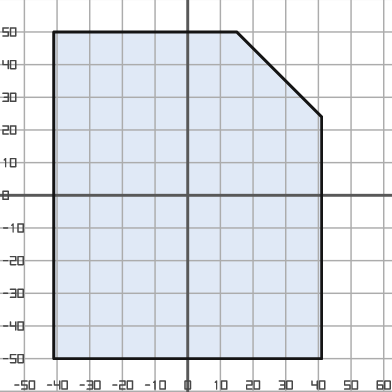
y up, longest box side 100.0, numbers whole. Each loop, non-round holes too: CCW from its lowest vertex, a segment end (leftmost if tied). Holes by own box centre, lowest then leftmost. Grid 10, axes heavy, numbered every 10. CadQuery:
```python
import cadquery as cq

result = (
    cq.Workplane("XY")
    .moveTo(-41.0, -50.0)
    .lineTo(41.0, -50.0)
    .lineTo(41.0, 24.0)
    .lineTo(15.0, 50.0)
    .lineTo(-41.0, 50.0)
    .close()
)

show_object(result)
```